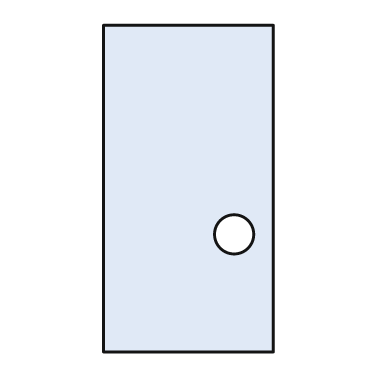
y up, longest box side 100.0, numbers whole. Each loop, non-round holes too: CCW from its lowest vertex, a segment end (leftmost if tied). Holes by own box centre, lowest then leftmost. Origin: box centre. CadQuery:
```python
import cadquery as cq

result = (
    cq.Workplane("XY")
    .moveTo(-26.0, -50.0)
    .lineTo(26.0, -50.0)
    .lineTo(26.0, 50.0)
    .lineTo(-26.0, 50.0)
    .close()
    .moveTo(14.0, -14.0)
    .circle(6.0)
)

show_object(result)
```